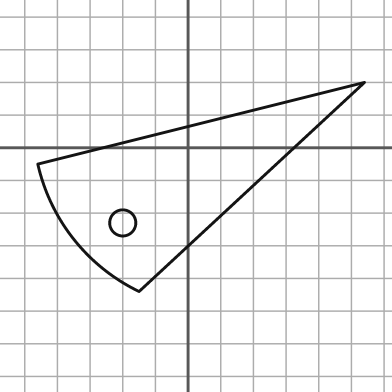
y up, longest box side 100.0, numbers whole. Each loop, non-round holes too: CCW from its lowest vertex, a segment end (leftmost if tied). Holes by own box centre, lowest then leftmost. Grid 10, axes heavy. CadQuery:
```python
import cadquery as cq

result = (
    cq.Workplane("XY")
    .moveTo(-15.0, -44.0)
    .lineTo(54.0, 20.0)
    .lineTo(-46.0, -5.0)
    .threePointArc((-35.0, -28.0), (-15.0, -44.0))
    .close()
    .moveTo(-20.0, -23.0)
    .circle(4.0)
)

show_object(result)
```